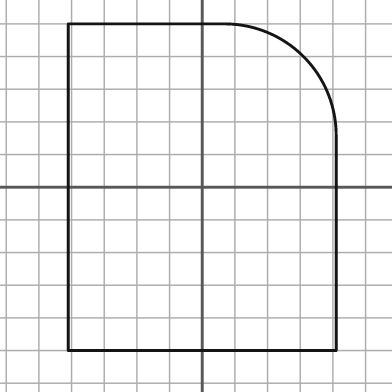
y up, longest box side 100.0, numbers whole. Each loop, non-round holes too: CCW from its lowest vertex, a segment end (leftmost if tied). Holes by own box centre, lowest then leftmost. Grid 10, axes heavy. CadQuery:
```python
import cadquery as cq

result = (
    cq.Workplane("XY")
    .moveTo(-41.0, -50.0)
    .lineTo(41.0, -50.0)
    .lineTo(41.0, 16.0)
    .threePointArc((31.0, 40.0), (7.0, 50.0))
    .lineTo(-41.0, 50.0)
    .close()
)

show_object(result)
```